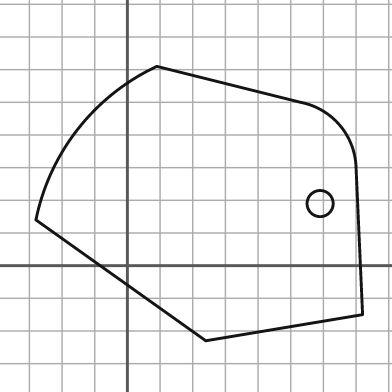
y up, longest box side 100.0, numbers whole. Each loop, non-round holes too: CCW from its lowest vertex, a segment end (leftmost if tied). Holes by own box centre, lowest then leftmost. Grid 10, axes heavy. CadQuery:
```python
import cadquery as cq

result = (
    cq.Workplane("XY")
    .moveTo(24.0, -23.0)
    .lineTo(72.0, -15.0)
    .lineTo(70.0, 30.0)
    .threePointArc((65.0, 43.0), (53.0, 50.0))
    .lineTo(9.0, 61.0)
    .threePointArc((-15.0, 42.0), (-28.0, 14.0))
    .close()
    .moveTo(59.0, 19.0)
    .circle(4.0)
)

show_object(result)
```